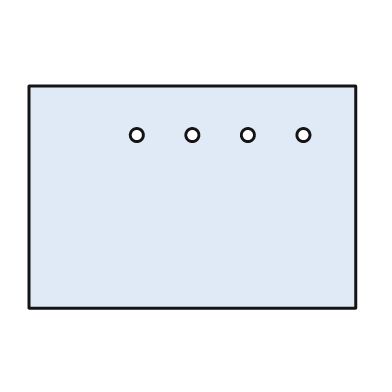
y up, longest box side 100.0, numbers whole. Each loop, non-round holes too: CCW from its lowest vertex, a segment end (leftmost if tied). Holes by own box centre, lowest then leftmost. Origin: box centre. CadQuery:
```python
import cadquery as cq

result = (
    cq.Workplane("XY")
    .moveTo(-50.0, -34.0)
    .lineTo(50.0, -34.0)
    .lineTo(50.0, 34.0)
    .lineTo(-50.0, 34.0)
    .close()
    .moveTo(-17.0, 19.0)
    .circle(2.0)
    .moveTo(0.0, 19.0)
    .circle(2.0)
    .moveTo(17.0, 19.0)
    .circle(2.0)
    .moveTo(34.0, 19.0)
    .circle(2.0)
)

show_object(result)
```